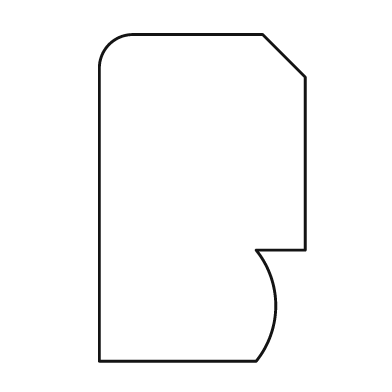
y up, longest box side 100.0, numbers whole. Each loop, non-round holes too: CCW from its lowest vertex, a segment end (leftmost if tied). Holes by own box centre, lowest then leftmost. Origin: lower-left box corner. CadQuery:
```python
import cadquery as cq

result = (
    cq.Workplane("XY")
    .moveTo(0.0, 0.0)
    .lineTo(48.0, 0.0)
    .threePointArc((54.0, 17.0), (48.0, 34.0))
    .lineTo(63.0, 34.0)
    .lineTo(63.0, 87.0)
    .lineTo(50.0, 100.0)
    .lineTo(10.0, 100.0)
    .threePointArc((3.0, 97.0), (0.0, 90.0))
    .close()
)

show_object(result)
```